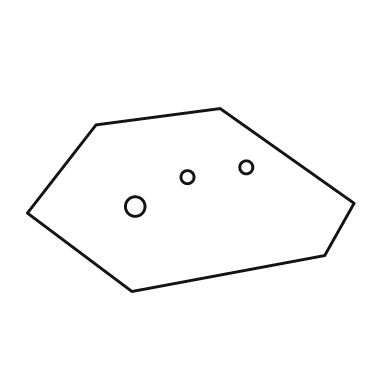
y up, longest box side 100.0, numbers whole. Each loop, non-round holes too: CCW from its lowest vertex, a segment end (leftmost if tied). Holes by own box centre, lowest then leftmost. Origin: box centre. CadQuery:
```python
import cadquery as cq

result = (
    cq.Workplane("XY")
    .moveTo(-18.0, -28.0)
    .lineTo(41.0, -17.0)
    .lineTo(50.0, -1.0)
    .lineTo(9.0, 28.0)
    .lineTo(-29.0, 23.0)
    .lineTo(-50.0, -4.0)
    .close()
    .moveTo(-17.0, -2.0)
    .circle(3.0)
    .moveTo(-1.0, 7.0)
    .circle(2.0)
    .moveTo(17.0, 10.0)
    .circle(2.0)
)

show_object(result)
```